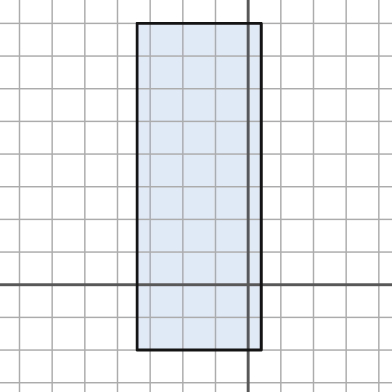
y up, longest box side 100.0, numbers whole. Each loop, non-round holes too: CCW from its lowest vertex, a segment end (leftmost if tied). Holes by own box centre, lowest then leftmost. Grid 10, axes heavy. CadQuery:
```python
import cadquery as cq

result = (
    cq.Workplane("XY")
    .moveTo(-34.0, -20.0)
    .lineTo(4.0, -20.0)
    .lineTo(4.0, 80.0)
    .lineTo(-34.0, 80.0)
    .close()
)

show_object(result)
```